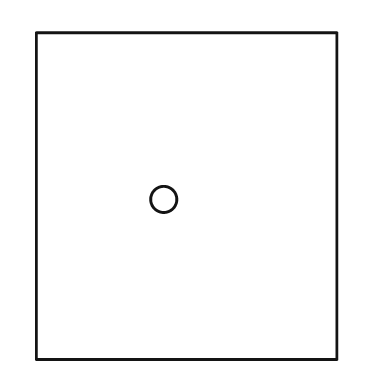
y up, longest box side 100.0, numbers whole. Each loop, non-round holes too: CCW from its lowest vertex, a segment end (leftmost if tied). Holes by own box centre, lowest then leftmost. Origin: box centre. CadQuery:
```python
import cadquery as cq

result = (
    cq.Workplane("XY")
    .moveTo(-46.0, -50.0)
    .lineTo(46.0, -50.0)
    .lineTo(46.0, 50.0)
    .lineTo(-46.0, 50.0)
    .close()
    .moveTo(-7.0, -1.0)
    .circle(4.0)
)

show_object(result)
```